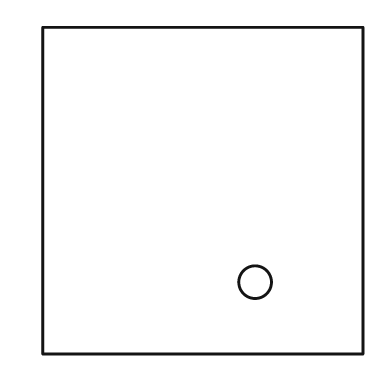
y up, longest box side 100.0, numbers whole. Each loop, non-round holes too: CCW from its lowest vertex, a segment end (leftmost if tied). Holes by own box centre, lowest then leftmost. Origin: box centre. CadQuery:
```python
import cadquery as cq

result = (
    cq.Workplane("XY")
    .moveTo(-49.0, -50.0)
    .lineTo(49.0, -50.0)
    .lineTo(49.0, 50.0)
    .lineTo(-49.0, 50.0)
    .close()
    .moveTo(16.0, -28.0)
    .circle(5.0)
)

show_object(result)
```